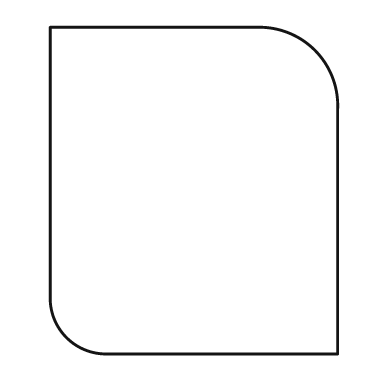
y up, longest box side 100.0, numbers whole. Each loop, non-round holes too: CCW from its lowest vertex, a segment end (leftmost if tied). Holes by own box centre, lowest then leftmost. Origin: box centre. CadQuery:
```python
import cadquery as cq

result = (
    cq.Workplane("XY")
    .moveTo(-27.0, -50.0)
    .lineTo(44.0, -50.0)
    .lineTo(44.0, 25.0)
    .threePointArc((37.0, 43.0), (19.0, 50.0))
    .lineTo(-44.0, 50.0)
    .lineTo(-44.0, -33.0)
    .threePointArc((-39.0, -45.0), (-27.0, -50.0))
    .close()
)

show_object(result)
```